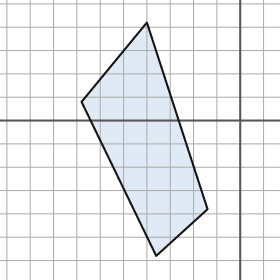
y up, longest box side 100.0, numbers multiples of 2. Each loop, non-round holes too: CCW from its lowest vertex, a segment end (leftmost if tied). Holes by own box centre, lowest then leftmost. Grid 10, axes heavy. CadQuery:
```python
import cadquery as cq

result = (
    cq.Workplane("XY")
    .moveTo(-36.0, -58.0)
    .lineTo(-14.0, -38.0)
    .lineTo(-40.0, 42.0)
    .lineTo(-68.0, 8.0)
    .close()
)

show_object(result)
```